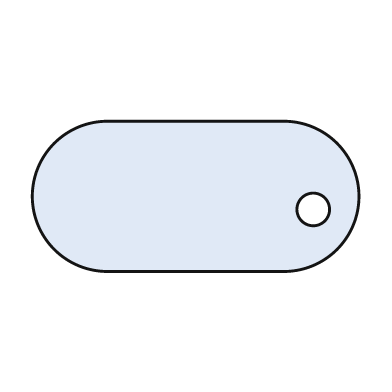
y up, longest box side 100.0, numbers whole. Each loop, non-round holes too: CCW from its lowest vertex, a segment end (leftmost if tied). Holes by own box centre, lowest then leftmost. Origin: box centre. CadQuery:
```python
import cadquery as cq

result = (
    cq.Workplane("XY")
    .moveTo(-27.0, -23.0)
    .lineTo(27.0, -23.0)
    .threePointArc((50.0, 0.0), (27.0, 23.0))
    .lineTo(-27.0, 23.0)
    .threePointArc((-50.0, 0.0), (-27.0, -23.0))
    .close()
    .moveTo(36.0, -4.0)
    .circle(5.0)
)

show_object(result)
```